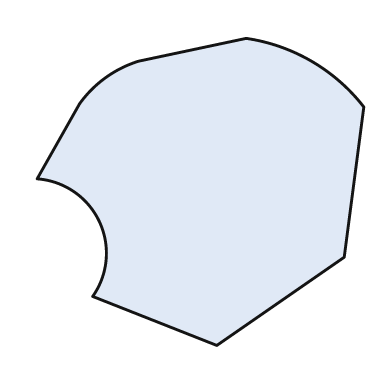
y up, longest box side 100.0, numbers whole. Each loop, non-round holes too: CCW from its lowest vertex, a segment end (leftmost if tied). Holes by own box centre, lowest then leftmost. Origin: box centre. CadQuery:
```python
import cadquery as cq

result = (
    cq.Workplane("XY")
    .moveTo(5.0, -47.0)
    .lineTo(44.0, -20.0)
    .lineTo(50.0, 26.0)
    .threePointArc((34.0, 40.0), (14.0, 47.0))
    .lineTo(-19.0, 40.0)
    .threePointArc((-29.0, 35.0), (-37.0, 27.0))
    .lineTo(-50.0, 4.0)
    .threePointArc((-31.0, -9.0), (-33.0, -32.0))
    .close()
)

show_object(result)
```